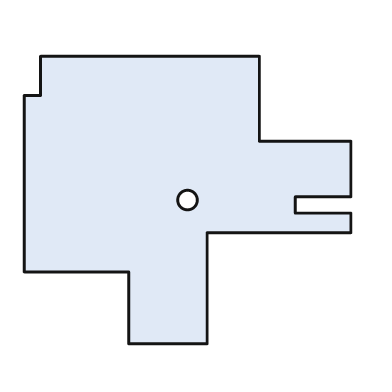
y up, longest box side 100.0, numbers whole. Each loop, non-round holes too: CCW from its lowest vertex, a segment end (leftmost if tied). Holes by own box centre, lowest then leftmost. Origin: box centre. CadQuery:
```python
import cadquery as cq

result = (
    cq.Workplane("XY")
    .moveTo(-18.0, -44.0)
    .lineTo(6.0, -44.0)
    .lineTo(6.0, -10.0)
    .lineTo(50.0, -10.0)
    .lineTo(50.0, -4.0)
    .lineTo(33.0, -4.0)
    .lineTo(33.0, 1.0)
    .lineTo(50.0, 1.0)
    .lineTo(50.0, 18.0)
    .lineTo(22.0, 18.0)
    .lineTo(22.0, 44.0)
    .lineTo(-45.0, 44.0)
    .lineTo(-45.0, 32.0)
    .lineTo(-50.0, 32.0)
    .lineTo(-50.0, -22.0)
    .lineTo(-18.0, -22.0)
    .close()
    .moveTo(0.0, 0.0)
    .circle(3.0)
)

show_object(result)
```